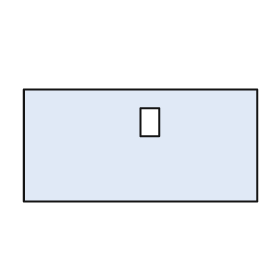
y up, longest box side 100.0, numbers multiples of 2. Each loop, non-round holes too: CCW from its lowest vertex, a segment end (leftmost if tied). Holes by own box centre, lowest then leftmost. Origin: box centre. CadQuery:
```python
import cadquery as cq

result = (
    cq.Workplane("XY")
    .moveTo(-50.0, -24.0)
    .lineTo(50.0, -24.0)
    .lineTo(50.0, 24.0)
    .lineTo(-50.0, 24.0)
    .close()
    .moveTo(0.0, 4.0)
    .lineTo(8.0, 4.0)
    .lineTo(8.0, 16.0)
    .lineTo(0.0, 16.0)
    .close()
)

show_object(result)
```